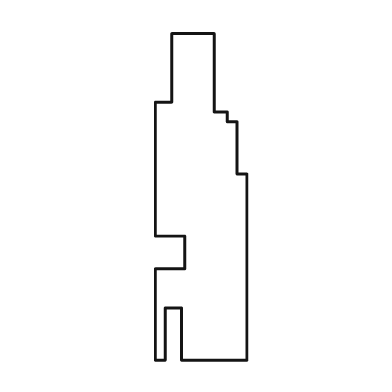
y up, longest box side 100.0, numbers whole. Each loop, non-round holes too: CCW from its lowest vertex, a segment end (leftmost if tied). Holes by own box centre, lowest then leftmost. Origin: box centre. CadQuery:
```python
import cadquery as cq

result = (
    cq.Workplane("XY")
    .moveTo(-14.0, -50.0)
    .lineTo(-11.0, -50.0)
    .lineTo(-11.0, -34.0)
    .lineTo(-6.0, -34.0)
    .lineTo(-6.0, -50.0)
    .lineTo(14.0, -50.0)
    .lineTo(14.0, 7.0)
    .lineTo(11.0, 7.0)
    .lineTo(11.0, 23.0)
    .lineTo(8.0, 23.0)
    .lineTo(8.0, 26.0)
    .lineTo(4.0, 26.0)
    .lineTo(4.0, 50.0)
    .lineTo(-9.0, 50.0)
    .lineTo(-9.0, 29.0)
    .lineTo(-14.0, 29.0)
    .lineTo(-14.0, -12.0)
    .lineTo(-5.0, -12.0)
    .lineTo(-5.0, -22.0)
    .lineTo(-14.0, -22.0)
    .close()
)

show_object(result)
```